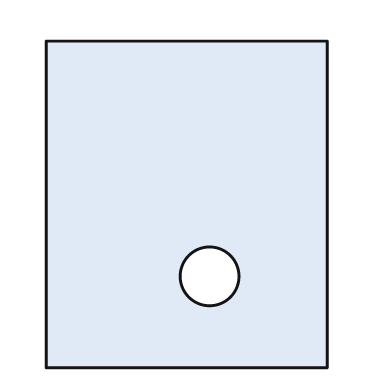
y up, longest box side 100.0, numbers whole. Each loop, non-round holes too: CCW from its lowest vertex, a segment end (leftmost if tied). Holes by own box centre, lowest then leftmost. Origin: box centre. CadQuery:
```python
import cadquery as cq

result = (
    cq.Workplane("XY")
    .moveTo(-43.0, -50.0)
    .lineTo(43.0, -50.0)
    .lineTo(43.0, 50.0)
    .lineTo(-43.0, 50.0)
    .close()
    .moveTo(7.0, -22.0)
    .circle(9.0)
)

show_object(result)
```